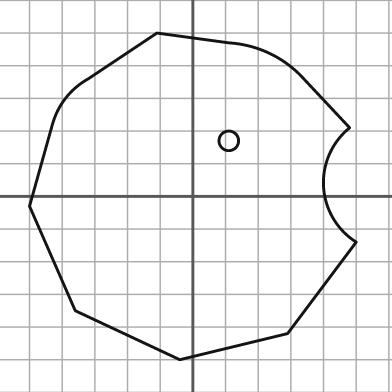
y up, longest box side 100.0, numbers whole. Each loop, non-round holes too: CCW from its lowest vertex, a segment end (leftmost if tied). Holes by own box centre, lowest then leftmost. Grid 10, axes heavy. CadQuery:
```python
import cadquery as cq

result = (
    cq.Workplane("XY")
    .moveTo(-4.0, -50.0)
    .lineTo(29.0, -42.0)
    .lineTo(50.0, -14.0)
    .threePointArc((40.0, 3.0), (48.0, 21.0))
    .lineTo(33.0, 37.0)
    .threePointArc((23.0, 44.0), (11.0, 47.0))
    .lineTo(-11.0, 50.0)
    .lineTo(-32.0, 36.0)
    .threePointArc((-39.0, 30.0), (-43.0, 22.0))
    .lineTo(-50.0, -3.0)
    .lineTo(-36.0, -35.0)
    .close()
    .moveTo(11.0, 17.0)
    .circle(3.0)
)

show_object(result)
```